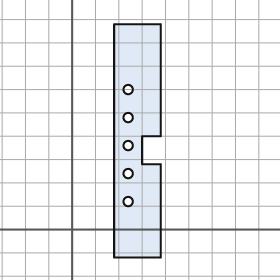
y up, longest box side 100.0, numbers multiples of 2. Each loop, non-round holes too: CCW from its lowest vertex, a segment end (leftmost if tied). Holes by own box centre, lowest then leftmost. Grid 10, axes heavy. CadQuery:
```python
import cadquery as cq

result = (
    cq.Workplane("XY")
    .moveTo(18.0, -12.0)
    .lineTo(38.0, -12.0)
    .lineTo(38.0, 28.0)
    .lineTo(30.0, 28.0)
    .lineTo(30.0, 40.0)
    .lineTo(38.0, 40.0)
    .lineTo(38.0, 88.0)
    .lineTo(18.0, 88.0)
    .close()
    .moveTo(24.0, 12.0)
    .circle(2.0)
    .moveTo(24.0, 24.0)
    .circle(2.0)
    .moveTo(24.0, 36.0)
    .circle(2.0)
    .moveTo(24.0, 48.0)
    .circle(2.0)
    .moveTo(24.0, 60.0)
    .circle(2.0)
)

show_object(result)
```